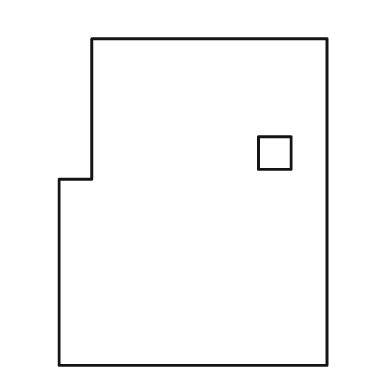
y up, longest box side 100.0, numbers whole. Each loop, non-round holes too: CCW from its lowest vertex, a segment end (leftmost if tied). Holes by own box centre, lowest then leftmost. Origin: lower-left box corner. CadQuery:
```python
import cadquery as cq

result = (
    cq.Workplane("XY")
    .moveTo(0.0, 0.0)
    .lineTo(82.0, 0.0)
    .lineTo(82.0, 100.0)
    .lineTo(10.0, 100.0)
    .lineTo(10.0, 57.0)
    .lineTo(0.0, 57.0)
    .close()
    .moveTo(61.0, 60.0)
    .lineTo(71.0, 60.0)
    .lineTo(71.0, 70.0)
    .lineTo(61.0, 70.0)
    .close()
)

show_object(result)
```